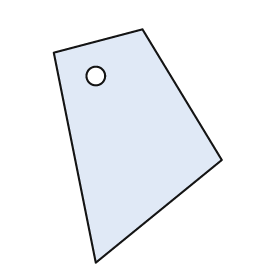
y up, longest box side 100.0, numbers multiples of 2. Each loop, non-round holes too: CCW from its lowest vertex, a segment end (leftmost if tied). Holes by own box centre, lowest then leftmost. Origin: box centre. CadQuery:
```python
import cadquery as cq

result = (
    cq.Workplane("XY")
    .moveTo(-18.0, -50.0)
    .lineTo(36.0, -6.0)
    .lineTo(2.0, 50.0)
    .lineTo(-36.0, 40.0)
    .close()
    .moveTo(-18.0, 30.0)
    .circle(4.0)
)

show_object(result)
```